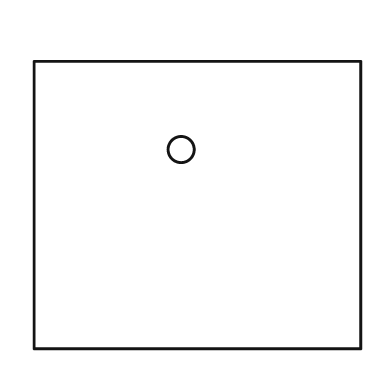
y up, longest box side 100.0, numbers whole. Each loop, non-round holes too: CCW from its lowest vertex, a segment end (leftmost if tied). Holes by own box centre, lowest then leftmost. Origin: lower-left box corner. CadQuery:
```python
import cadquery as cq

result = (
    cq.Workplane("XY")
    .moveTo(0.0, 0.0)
    .lineTo(100.0, 0.0)
    .lineTo(100.0, 88.0)
    .lineTo(0.0, 88.0)
    .close()
    .moveTo(45.0, 61.0)
    .circle(4.0)
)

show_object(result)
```